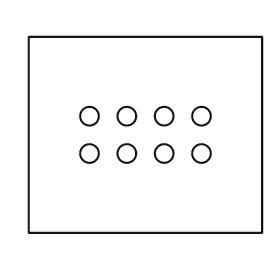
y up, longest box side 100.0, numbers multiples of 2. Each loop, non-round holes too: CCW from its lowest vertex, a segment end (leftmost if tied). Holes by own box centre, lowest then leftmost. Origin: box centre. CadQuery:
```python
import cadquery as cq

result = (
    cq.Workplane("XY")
    .moveTo(-50.0, -42.0)
    .lineTo(50.0, -42.0)
    .lineTo(50.0, 42.0)
    .lineTo(-50.0, 42.0)
    .close()
    .moveTo(-24.0, -8.0)
    .circle(4.0)
    .moveTo(-8.0, -8.0)
    .circle(4.0)
    .moveTo(8.0, -8.0)
    .circle(4.0)
    .moveTo(24.0, -8.0)
    .circle(4.0)
    .moveTo(-24.0, 8.0)
    .circle(4.0)
    .moveTo(-8.0, 8.0)
    .circle(4.0)
    .moveTo(8.0, 8.0)
    .circle(4.0)
    .moveTo(24.0, 8.0)
    .circle(4.0)
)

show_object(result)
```